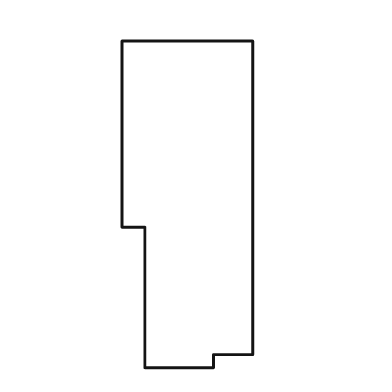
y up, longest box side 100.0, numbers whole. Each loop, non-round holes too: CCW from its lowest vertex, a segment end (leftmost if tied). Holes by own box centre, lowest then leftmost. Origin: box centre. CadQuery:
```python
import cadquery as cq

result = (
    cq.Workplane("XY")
    .moveTo(-13.0, -50.0)
    .lineTo(8.0, -50.0)
    .lineTo(8.0, -46.0)
    .lineTo(20.0, -46.0)
    .lineTo(20.0, 50.0)
    .lineTo(-20.0, 50.0)
    .lineTo(-20.0, -7.0)
    .lineTo(-13.0, -7.0)
    .close()
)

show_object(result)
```